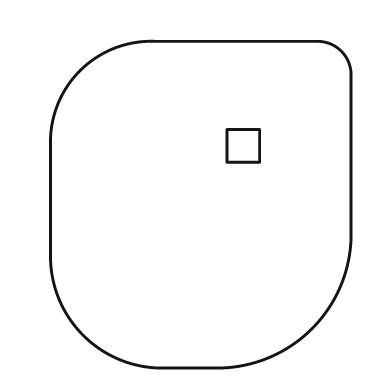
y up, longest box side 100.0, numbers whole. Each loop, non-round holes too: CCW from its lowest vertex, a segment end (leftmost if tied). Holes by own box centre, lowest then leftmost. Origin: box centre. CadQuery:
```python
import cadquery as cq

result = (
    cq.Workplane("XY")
    .moveTo(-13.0, -50.0)
    .lineTo(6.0, -50.0)
    .threePointArc((34.0, -38.0), (46.0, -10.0))
    .lineTo(46.0, 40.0)
    .threePointArc((43.0, 47.0), (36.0, 50.0))
    .lineTo(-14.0, 50.0)
    .threePointArc((-37.0, 41.0), (-46.0, 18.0))
    .lineTo(-46.0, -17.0)
    .threePointArc((-36.0, -40.0), (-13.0, -50.0))
    .close()
    .moveTo(8.0, 13.0)
    .lineTo(18.0, 13.0)
    .lineTo(18.0, 23.0)
    .lineTo(8.0, 23.0)
    .close()
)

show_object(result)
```